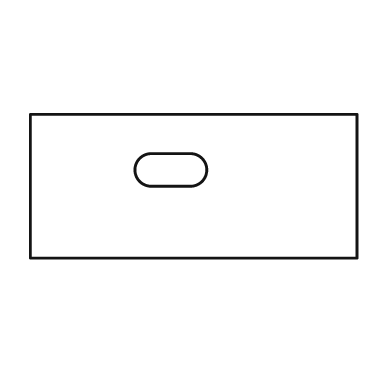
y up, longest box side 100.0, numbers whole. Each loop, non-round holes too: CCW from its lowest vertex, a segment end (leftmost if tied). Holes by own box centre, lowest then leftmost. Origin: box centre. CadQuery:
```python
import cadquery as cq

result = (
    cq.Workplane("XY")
    .moveTo(-50.0, -22.0)
    .lineTo(50.0, -22.0)
    .lineTo(50.0, 22.0)
    .lineTo(-50.0, 22.0)
    .close()
    .moveTo(-13.0, 0.0)
    .lineTo(-1.0, 0.0)
    .threePointArc((4.0, 5.0), (-1.0, 10.0))
    .lineTo(-13.0, 10.0)
    .threePointArc((-18.0, 5.0), (-13.0, 0.0))
    .close()
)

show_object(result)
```